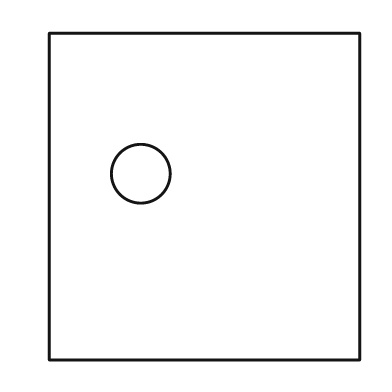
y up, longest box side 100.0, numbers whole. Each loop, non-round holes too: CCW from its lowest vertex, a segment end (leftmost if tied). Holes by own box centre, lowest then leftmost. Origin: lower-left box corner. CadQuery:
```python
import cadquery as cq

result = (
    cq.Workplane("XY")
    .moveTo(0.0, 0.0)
    .lineTo(95.0, 0.0)
    .lineTo(95.0, 100.0)
    .lineTo(0.0, 100.0)
    .close()
    .moveTo(28.0, 57.0)
    .circle(9.0)
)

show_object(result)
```